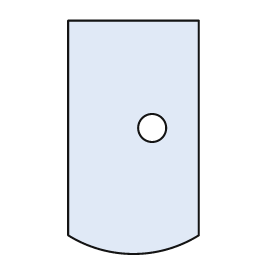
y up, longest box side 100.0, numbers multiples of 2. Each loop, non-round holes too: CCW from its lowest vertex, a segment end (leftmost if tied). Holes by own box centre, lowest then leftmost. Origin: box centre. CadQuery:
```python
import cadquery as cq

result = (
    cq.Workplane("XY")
    .moveTo(-28.0, -42.0)
    .threePointArc((0.0, -50.0), (28.0, -42.0))
    .lineTo(28.0, 50.0)
    .lineTo(-28.0, 50.0)
    .close()
    .moveTo(8.0, 4.0)
    .circle(6.0)
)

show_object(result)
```